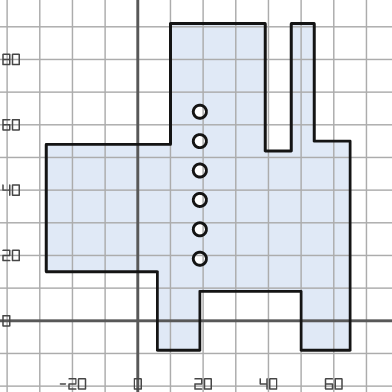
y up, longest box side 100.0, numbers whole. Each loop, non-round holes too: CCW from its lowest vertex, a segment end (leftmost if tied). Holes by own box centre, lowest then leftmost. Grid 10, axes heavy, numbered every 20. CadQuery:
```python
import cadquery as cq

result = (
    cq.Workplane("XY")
    .moveTo(6.0, -9.0)
    .lineTo(19.0, -9.0)
    .lineTo(19.0, 9.0)
    .lineTo(50.0, 9.0)
    .lineTo(50.0, -9.0)
    .lineTo(65.0, -9.0)
    .lineTo(65.0, 55.0)
    .lineTo(54.0, 55.0)
    .lineTo(54.0, 91.0)
    .lineTo(47.0, 91.0)
    .lineTo(47.0, 52.0)
    .lineTo(39.0, 52.0)
    .lineTo(39.0, 91.0)
    .lineTo(10.0, 91.0)
    .lineTo(10.0, 54.0)
    .lineTo(-28.0, 54.0)
    .lineTo(-28.0, 15.0)
    .lineTo(6.0, 15.0)
    .close()
    .moveTo(19.0, 19.0)
    .circle(2.0)
    .moveTo(19.0, 28.0)
    .circle(2.0)
    .moveTo(19.0, 37.0)
    .circle(2.0)
    .moveTo(19.0, 46.0)
    .circle(2.0)
    .moveTo(19.0, 55.0)
    .circle(2.0)
    .moveTo(19.0, 64.0)
    .circle(2.0)
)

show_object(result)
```